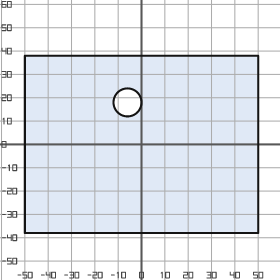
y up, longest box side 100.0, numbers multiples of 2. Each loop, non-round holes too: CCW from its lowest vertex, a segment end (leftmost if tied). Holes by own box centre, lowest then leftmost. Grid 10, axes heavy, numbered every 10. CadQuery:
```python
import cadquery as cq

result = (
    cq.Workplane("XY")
    .moveTo(-50.0, -38.0)
    .lineTo(50.0, -38.0)
    .lineTo(50.0, 38.0)
    .lineTo(-50.0, 38.0)
    .close()
    .moveTo(-6.0, 18.0)
    .circle(6.0)
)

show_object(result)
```